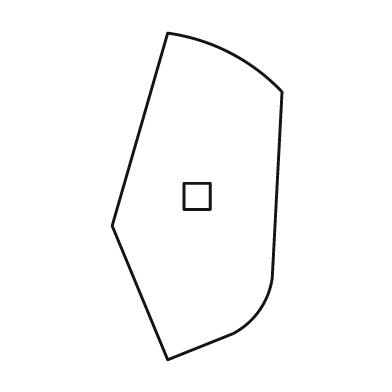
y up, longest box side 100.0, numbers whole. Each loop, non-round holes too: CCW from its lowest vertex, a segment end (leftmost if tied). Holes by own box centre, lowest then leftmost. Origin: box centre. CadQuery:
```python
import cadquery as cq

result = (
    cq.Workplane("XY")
    .moveTo(-9.0, -50.0)
    .lineTo(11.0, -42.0)
    .threePointArc((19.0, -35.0), (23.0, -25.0))
    .lineTo(26.0, 32.0)
    .threePointArc((10.0, 44.0), (-9.0, 50.0))
    .lineTo(-26.0, -9.0)
    .close()
    .moveTo(-4.0, -4.0)
    .lineTo(4.0, -4.0)
    .lineTo(4.0, 4.0)
    .lineTo(-4.0, 4.0)
    .close()
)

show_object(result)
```